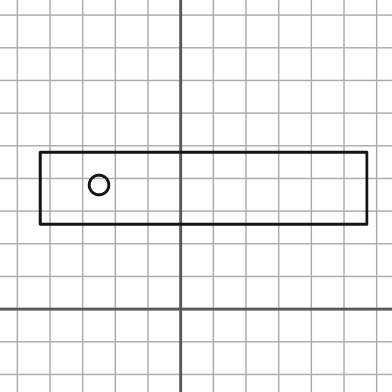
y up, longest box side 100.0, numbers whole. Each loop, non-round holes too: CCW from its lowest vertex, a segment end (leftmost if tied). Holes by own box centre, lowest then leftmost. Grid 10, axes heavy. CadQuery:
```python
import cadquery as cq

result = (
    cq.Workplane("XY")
    .moveTo(-43.0, 26.0)
    .lineTo(57.0, 26.0)
    .lineTo(57.0, 48.0)
    .lineTo(-43.0, 48.0)
    .close()
    .moveTo(-25.0, 38.0)
    .circle(3.0)
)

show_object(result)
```